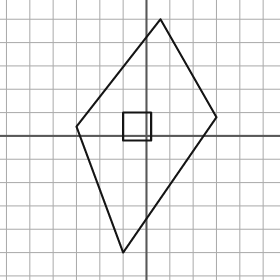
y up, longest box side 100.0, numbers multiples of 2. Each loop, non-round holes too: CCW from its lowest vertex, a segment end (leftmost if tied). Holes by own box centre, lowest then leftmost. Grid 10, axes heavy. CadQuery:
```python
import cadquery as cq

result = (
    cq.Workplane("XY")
    .moveTo(-10.0, -50.0)
    .lineTo(30.0, 8.0)
    .lineTo(6.0, 50.0)
    .lineTo(-30.0, 4.0)
    .close()
    .moveTo(-10.0, -2.0)
    .lineTo(2.0, -2.0)
    .lineTo(2.0, 10.0)
    .lineTo(-10.0, 10.0)
    .close()
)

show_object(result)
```